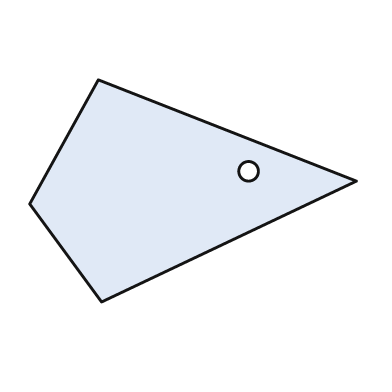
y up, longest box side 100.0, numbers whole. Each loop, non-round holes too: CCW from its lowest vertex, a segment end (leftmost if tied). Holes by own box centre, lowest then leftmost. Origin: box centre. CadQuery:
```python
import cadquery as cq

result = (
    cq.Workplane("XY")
    .moveTo(-28.0, -34.0)
    .lineTo(50.0, 3.0)
    .lineTo(-29.0, 34.0)
    .lineTo(-50.0, -4.0)
    .close()
    .moveTo(17.0, 6.0)
    .circle(3.0)
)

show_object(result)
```